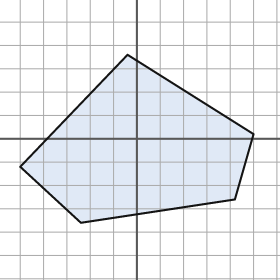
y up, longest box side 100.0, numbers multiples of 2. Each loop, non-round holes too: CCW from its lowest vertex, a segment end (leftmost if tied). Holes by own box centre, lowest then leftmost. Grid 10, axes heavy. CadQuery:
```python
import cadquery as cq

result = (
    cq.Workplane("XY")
    .moveTo(-24.0, -36.0)
    .lineTo(42.0, -26.0)
    .lineTo(50.0, 2.0)
    .lineTo(-4.0, 36.0)
    .lineTo(-50.0, -12.0)
    .close()
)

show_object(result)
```